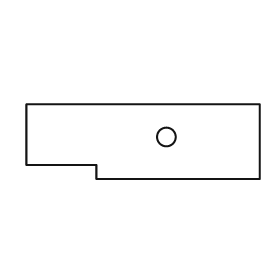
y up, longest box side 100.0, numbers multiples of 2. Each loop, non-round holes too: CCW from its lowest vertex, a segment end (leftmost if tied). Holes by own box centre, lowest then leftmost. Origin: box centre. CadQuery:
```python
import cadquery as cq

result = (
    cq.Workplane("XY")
    .moveTo(-20.0, -16.0)
    .lineTo(50.0, -16.0)
    .lineTo(50.0, 16.0)
    .lineTo(-50.0, 16.0)
    .lineTo(-50.0, -10.0)
    .lineTo(-20.0, -10.0)
    .close()
    .moveTo(10.0, 2.0)
    .circle(4.0)
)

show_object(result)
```